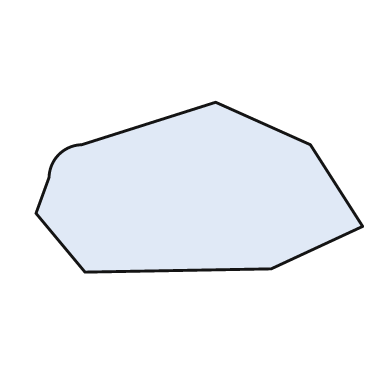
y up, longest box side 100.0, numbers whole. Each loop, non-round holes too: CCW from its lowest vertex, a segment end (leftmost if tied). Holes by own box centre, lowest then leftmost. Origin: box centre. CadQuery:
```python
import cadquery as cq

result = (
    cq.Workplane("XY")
    .moveTo(-35.0, -26.0)
    .lineTo(22.0, -25.0)
    .lineTo(50.0, -12.0)
    .lineTo(34.0, 13.0)
    .lineTo(5.0, 26.0)
    .lineTo(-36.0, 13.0)
    .threePointArc((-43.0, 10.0), (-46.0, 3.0))
    .lineTo(-50.0, -8.0)
    .close()
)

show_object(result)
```